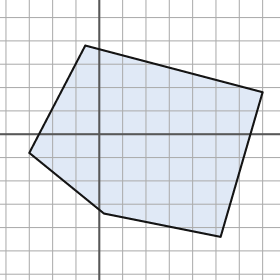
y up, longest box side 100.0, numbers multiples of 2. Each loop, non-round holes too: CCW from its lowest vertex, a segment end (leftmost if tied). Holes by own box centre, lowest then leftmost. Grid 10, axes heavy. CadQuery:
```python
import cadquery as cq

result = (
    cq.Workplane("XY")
    .moveTo(52.0, -44.0)
    .lineTo(70.0, 18.0)
    .lineTo(-6.0, 38.0)
    .lineTo(-30.0, -8.0)
    .lineTo(2.0, -34.0)
    .close()
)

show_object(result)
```